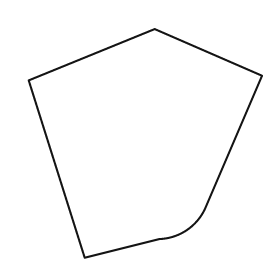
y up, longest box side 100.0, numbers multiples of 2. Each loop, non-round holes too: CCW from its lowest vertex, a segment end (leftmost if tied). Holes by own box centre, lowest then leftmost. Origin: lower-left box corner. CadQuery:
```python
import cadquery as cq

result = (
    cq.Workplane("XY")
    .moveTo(24.0, 0.0)
    .lineTo(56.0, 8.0)
    .threePointArc((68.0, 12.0), (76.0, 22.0))
    .lineTo(100.0, 78.0)
    .lineTo(54.0, 98.0)
    .lineTo(0.0, 76.0)
    .close()
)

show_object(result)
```